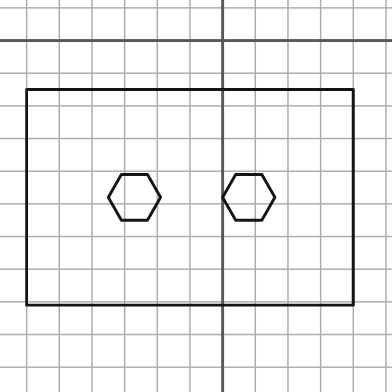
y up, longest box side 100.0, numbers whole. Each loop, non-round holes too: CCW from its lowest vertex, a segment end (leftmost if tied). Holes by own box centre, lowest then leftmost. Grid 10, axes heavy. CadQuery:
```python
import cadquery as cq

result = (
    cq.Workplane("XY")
    .moveTo(-60.0, -81.0)
    .lineTo(40.0, -81.0)
    .lineTo(40.0, -15.0)
    .lineTo(-60.0, -15.0)
    .close()
    .moveTo(-31.0, -55.0)
    .lineTo(-23.0, -55.0)
    .lineTo(-19.0, -48.0)
    .lineTo(-23.0, -41.0)
    .lineTo(-31.0, -41.0)
    .lineTo(-35.0, -48.0)
    .close()
    .moveTo(4.0, -55.0)
    .lineTo(12.0, -55.0)
    .lineTo(16.0, -48.0)
    .lineTo(12.0, -41.0)
    .lineTo(4.0, -41.0)
    .lineTo(0.0, -48.0)
    .close()
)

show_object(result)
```